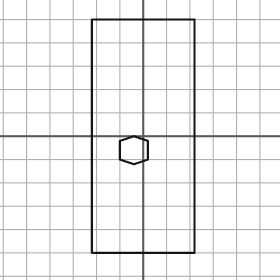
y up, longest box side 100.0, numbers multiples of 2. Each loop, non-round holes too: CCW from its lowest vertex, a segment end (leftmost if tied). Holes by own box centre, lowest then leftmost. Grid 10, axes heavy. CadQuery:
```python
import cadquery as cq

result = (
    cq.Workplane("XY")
    .moveTo(-22.0, -50.0)
    .lineTo(22.0, -50.0)
    .lineTo(22.0, 50.0)
    .lineTo(-22.0, 50.0)
    .close()
    .moveTo(-4.0, -12.0)
    .lineTo(2.0, -10.0)
    .lineTo(2.0, -2.0)
    .lineTo(-4.0, 0.0)
    .lineTo(-10.0, -2.0)
    .lineTo(-10.0, -10.0)
    .close()
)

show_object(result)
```